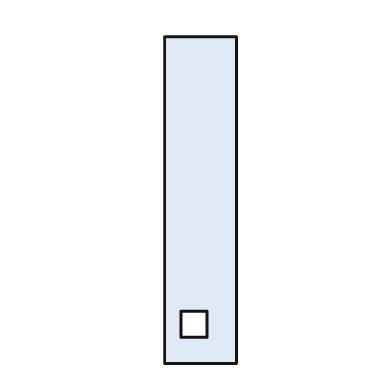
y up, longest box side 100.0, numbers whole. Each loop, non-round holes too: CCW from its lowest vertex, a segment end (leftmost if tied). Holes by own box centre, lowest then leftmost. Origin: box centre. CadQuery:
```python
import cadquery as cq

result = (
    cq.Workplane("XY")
    .moveTo(-11.0, -50.0)
    .lineTo(11.0, -50.0)
    .lineTo(11.0, 50.0)
    .lineTo(-11.0, 50.0)
    .close()
    .moveTo(-6.0, -42.0)
    .lineTo(2.0, -42.0)
    .lineTo(2.0, -34.0)
    .lineTo(-6.0, -34.0)
    .close()
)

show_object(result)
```